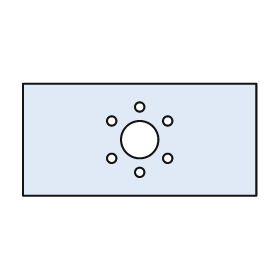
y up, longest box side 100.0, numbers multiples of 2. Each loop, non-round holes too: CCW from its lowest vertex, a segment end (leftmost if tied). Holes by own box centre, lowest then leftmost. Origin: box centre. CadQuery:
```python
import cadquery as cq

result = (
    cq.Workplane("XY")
    .moveTo(-50.0, -24.0)
    .lineTo(50.0, -24.0)
    .lineTo(50.0, 24.0)
    .lineTo(-50.0, 24.0)
    .close()
    .moveTo(0.0, -14.0)
    .circle(2.0)
    .moveTo(-12.0, -8.0)
    .circle(2.0)
    .moveTo(12.0, -8.0)
    .circle(2.0)
    .moveTo(0.0, 0.0)
    .circle(8.0)
    .moveTo(-12.0, 8.0)
    .circle(2.0)
    .moveTo(12.0, 8.0)
    .circle(2.0)
    .moveTo(0.0, 14.0)
    .circle(2.0)
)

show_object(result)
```